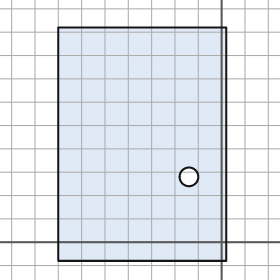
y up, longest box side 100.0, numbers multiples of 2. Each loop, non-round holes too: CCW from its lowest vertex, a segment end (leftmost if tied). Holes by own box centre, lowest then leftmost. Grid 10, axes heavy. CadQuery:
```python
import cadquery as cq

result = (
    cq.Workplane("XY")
    .moveTo(-70.0, -8.0)
    .lineTo(2.0, -8.0)
    .lineTo(2.0, 92.0)
    .lineTo(-70.0, 92.0)
    .close()
    .moveTo(-14.0, 28.0)
    .circle(4.0)
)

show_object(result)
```